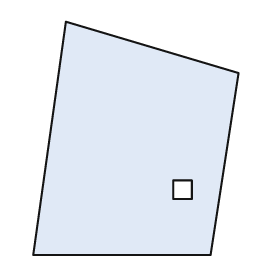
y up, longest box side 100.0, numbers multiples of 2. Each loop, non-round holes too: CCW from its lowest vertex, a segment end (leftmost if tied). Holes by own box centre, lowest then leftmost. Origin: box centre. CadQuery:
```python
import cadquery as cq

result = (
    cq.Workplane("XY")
    .moveTo(-44.0, -50.0)
    .lineTo(32.0, -50.0)
    .lineTo(44.0, 28.0)
    .lineTo(-30.0, 50.0)
    .close()
    .moveTo(16.0, -26.0)
    .lineTo(24.0, -26.0)
    .lineTo(24.0, -18.0)
    .lineTo(16.0, -18.0)
    .close()
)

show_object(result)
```